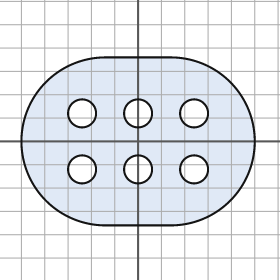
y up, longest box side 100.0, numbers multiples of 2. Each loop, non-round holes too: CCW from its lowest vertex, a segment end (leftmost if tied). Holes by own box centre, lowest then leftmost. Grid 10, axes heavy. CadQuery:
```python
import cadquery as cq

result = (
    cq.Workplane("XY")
    .moveTo(-14.0, -36.0)
    .lineTo(14.0, -36.0)
    .threePointArc((50.0, 0.0), (14.0, 36.0))
    .lineTo(-14.0, 36.0)
    .threePointArc((-50.0, 0.0), (-14.0, -36.0))
    .close()
    .moveTo(-24.0, -12.0)
    .circle(6.0)
    .moveTo(0.0, -12.0)
    .circle(6.0)
    .moveTo(24.0, -12.0)
    .circle(6.0)
    .moveTo(-24.0, 12.0)
    .circle(6.0)
    .moveTo(0.0, 12.0)
    .circle(6.0)
    .moveTo(24.0, 12.0)
    .circle(6.0)
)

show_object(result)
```